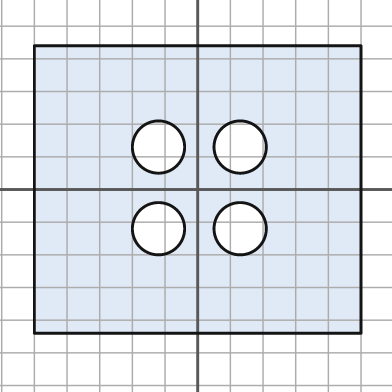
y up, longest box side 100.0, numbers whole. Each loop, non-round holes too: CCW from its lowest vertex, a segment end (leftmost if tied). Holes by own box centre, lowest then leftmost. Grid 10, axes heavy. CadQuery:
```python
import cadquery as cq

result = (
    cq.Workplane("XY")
    .moveTo(-50.0, -44.0)
    .lineTo(50.0, -44.0)
    .lineTo(50.0, 44.0)
    .lineTo(-50.0, 44.0)
    .close()
    .moveTo(-12.0, -12.0)
    .circle(8.0)
    .moveTo(13.0, -12.0)
    .circle(8.0)
    .moveTo(-12.0, 13.0)
    .circle(8.0)
    .moveTo(13.0, 13.0)
    .circle(8.0)
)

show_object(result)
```